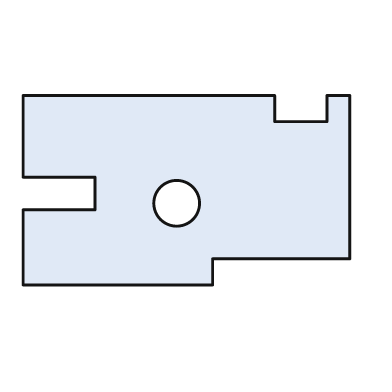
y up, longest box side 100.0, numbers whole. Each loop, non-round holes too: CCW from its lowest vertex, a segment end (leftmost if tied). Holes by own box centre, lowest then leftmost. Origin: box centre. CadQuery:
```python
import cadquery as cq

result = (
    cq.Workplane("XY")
    .moveTo(-50.0, -29.0)
    .lineTo(8.0, -29.0)
    .lineTo(8.0, -21.0)
    .lineTo(50.0, -21.0)
    .lineTo(50.0, 29.0)
    .lineTo(43.0, 29.0)
    .lineTo(43.0, 21.0)
    .lineTo(27.0, 21.0)
    .lineTo(27.0, 29.0)
    .lineTo(-50.0, 29.0)
    .lineTo(-50.0, 4.0)
    .lineTo(-28.0, 4.0)
    .lineTo(-28.0, -6.0)
    .lineTo(-50.0, -6.0)
    .close()
    .moveTo(-3.0, -4.0)
    .circle(7.0)
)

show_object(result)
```